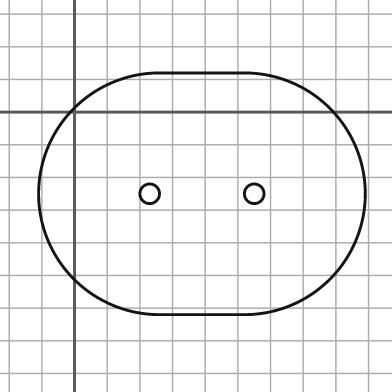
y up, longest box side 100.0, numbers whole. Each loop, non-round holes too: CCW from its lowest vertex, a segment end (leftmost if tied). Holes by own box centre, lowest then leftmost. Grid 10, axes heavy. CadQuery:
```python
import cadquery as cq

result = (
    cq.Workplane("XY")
    .moveTo(26.0, -62.0)
    .lineTo(52.0, -62.0)
    .threePointArc((89.0, -25.0), (52.0, 12.0))
    .lineTo(26.0, 12.0)
    .threePointArc((-11.0, -25.0), (26.0, -62.0))
    .close()
    .moveTo(23.0, -25.0)
    .circle(3.0)
    .moveTo(55.0, -25.0)
    .circle(3.0)
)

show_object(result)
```